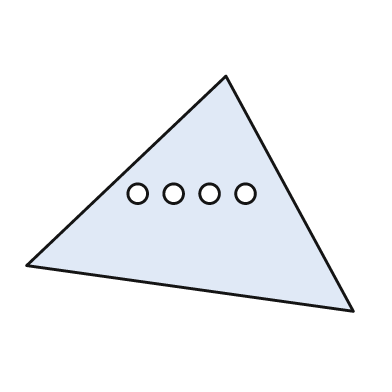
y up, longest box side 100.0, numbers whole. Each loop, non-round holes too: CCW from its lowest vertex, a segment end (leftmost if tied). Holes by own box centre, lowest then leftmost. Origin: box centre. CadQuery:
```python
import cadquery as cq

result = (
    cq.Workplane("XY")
    .moveTo(50.0, -36.0)
    .lineTo(11.0, 36.0)
    .lineTo(-50.0, -22.0)
    .close()
    .moveTo(-16.0, 0.0)
    .circle(3.0)
    .moveTo(-5.0, 0.0)
    .circle(3.0)
    .moveTo(6.0, 0.0)
    .circle(3.0)
    .moveTo(17.0, 0.0)
    .circle(3.0)
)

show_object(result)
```